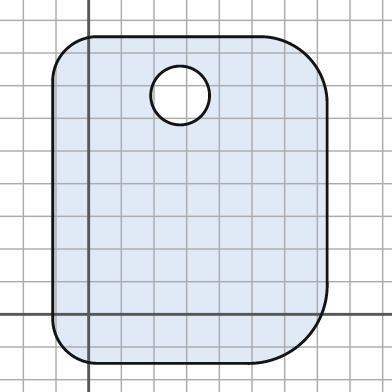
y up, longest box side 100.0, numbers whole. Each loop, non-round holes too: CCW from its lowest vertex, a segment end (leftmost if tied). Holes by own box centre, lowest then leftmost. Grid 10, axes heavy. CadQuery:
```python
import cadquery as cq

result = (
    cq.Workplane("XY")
    .moveTo(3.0, -15.0)
    .lineTo(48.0, -15.0)
    .threePointArc((66.0, -8.0), (73.0, 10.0))
    .lineTo(73.0, 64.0)
    .threePointArc((67.0, 79.0), (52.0, 85.0))
    .lineTo(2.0, 85.0)
    .threePointArc((-7.0, 81.0), (-11.0, 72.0))
    .lineTo(-11.0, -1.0)
    .threePointArc((-7.0, -11.0), (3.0, -15.0))
    .close()
    .moveTo(28.0, 67.0)
    .circle(9.0)
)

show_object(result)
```